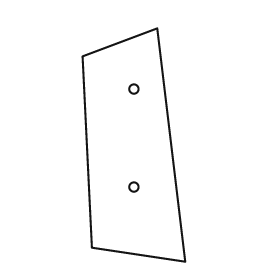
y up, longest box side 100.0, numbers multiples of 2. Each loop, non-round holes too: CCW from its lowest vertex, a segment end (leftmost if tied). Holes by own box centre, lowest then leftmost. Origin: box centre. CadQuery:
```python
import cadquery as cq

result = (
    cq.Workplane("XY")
    .moveTo(22.0, -50.0)
    .lineTo(10.0, 50.0)
    .lineTo(-22.0, 38.0)
    .lineTo(-18.0, -44.0)
    .close()
    .moveTo(0.0, -18.0)
    .circle(2.0)
    .moveTo(0.0, 24.0)
    .circle(2.0)
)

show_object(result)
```